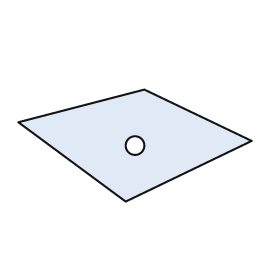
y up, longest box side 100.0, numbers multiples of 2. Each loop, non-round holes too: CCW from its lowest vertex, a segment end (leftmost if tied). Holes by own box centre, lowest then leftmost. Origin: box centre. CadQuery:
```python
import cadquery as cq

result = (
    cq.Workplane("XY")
    .moveTo(-4.0, -24.0)
    .lineTo(50.0, 2.0)
    .lineTo(4.0, 24.0)
    .lineTo(-50.0, 10.0)
    .close()
    .moveTo(0.0, 0.0)
    .circle(4.0)
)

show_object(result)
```